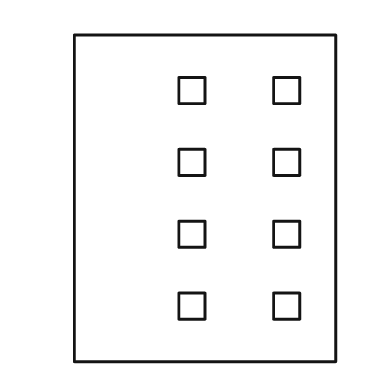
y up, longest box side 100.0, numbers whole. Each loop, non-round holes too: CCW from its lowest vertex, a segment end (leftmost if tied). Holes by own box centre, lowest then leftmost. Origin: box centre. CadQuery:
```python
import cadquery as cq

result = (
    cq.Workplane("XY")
    .moveTo(-40.0, -50.0)
    .lineTo(40.0, -50.0)
    .lineTo(40.0, 50.0)
    .lineTo(-40.0, 50.0)
    .close()
    .moveTo(-8.0, -37.0)
    .lineTo(0.0, -37.0)
    .lineTo(0.0, -29.0)
    .lineTo(-8.0, -29.0)
    .close()
    .moveTo(21.0, -37.0)
    .lineTo(29.0, -37.0)
    .lineTo(29.0, -29.0)
    .lineTo(21.0, -29.0)
    .close()
    .moveTo(-8.0, -15.0)
    .lineTo(0.0, -15.0)
    .lineTo(0.0, -7.0)
    .lineTo(-8.0, -7.0)
    .close()
    .moveTo(21.0, -15.0)
    .lineTo(29.0, -15.0)
    .lineTo(29.0, -7.0)
    .lineTo(21.0, -7.0)
    .close()
    .moveTo(-8.0, 7.0)
    .lineTo(0.0, 7.0)
    .lineTo(0.0, 15.0)
    .lineTo(-8.0, 15.0)
    .close()
    .moveTo(21.0, 7.0)
    .lineTo(29.0, 7.0)
    .lineTo(29.0, 15.0)
    .lineTo(21.0, 15.0)
    .close()
    .moveTo(-8.0, 29.0)
    .lineTo(0.0, 29.0)
    .lineTo(0.0, 37.0)
    .lineTo(-8.0, 37.0)
    .close()
    .moveTo(21.0, 29.0)
    .lineTo(29.0, 29.0)
    .lineTo(29.0, 37.0)
    .lineTo(21.0, 37.0)
    .close()
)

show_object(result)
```